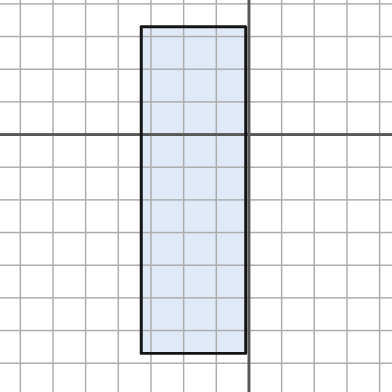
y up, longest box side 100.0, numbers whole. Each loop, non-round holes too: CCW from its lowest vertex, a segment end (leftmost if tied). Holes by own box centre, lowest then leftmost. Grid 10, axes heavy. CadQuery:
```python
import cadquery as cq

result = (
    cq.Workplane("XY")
    .moveTo(-33.0, -67.0)
    .lineTo(-1.0, -67.0)
    .lineTo(-1.0, 33.0)
    .lineTo(-33.0, 33.0)
    .close()
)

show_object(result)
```